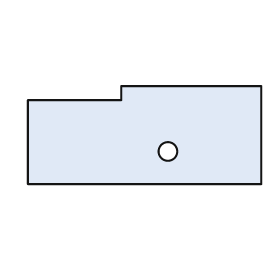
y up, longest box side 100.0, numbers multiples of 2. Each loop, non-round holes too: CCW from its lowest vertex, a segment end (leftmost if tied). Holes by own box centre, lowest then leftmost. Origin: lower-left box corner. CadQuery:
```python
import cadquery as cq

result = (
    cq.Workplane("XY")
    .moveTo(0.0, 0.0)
    .lineTo(100.0, 0.0)
    .lineTo(100.0, 42.0)
    .lineTo(40.0, 42.0)
    .lineTo(40.0, 36.0)
    .lineTo(0.0, 36.0)
    .close()
    .moveTo(60.0, 14.0)
    .circle(4.0)
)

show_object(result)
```